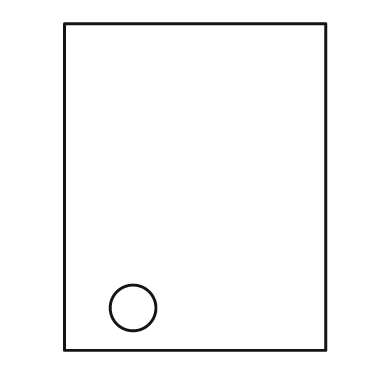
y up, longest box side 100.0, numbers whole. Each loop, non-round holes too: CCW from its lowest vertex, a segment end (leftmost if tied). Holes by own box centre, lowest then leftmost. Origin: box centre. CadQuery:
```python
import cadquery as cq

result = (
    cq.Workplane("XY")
    .moveTo(-40.0, -50.0)
    .lineTo(40.0, -50.0)
    .lineTo(40.0, 50.0)
    .lineTo(-40.0, 50.0)
    .close()
    .moveTo(-19.0, -37.0)
    .circle(7.0)
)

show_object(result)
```